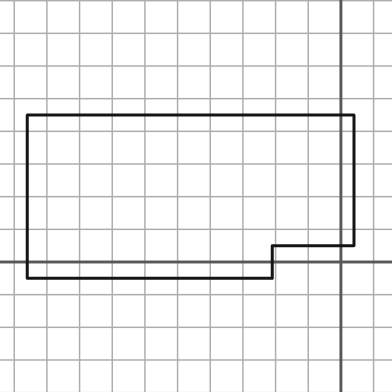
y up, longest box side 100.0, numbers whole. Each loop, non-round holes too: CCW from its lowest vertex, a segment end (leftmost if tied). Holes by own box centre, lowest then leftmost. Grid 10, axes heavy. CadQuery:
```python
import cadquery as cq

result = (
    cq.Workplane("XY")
    .moveTo(-96.0, -5.0)
    .lineTo(-21.0, -5.0)
    .lineTo(-21.0, 5.0)
    .lineTo(4.0, 5.0)
    .lineTo(4.0, 45.0)
    .lineTo(-96.0, 45.0)
    .close()
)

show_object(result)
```